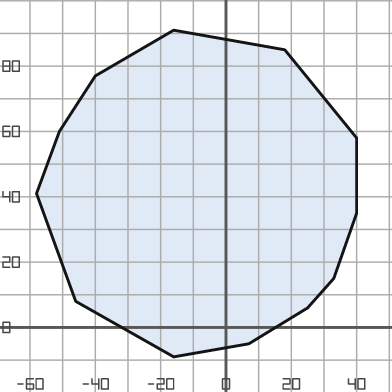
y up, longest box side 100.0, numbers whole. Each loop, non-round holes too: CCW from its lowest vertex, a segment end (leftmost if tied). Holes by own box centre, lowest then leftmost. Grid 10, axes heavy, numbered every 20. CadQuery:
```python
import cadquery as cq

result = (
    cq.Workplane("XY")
    .moveTo(-16.0, -9.0)
    .lineTo(7.0, -5.0)
    .lineTo(25.0, 6.0)
    .lineTo(33.0, 15.0)
    .lineTo(40.0, 35.0)
    .lineTo(40.0, 58.0)
    .lineTo(18.0, 85.0)
    .lineTo(-16.0, 91.0)
    .lineTo(-40.0, 77.0)
    .lineTo(-51.0, 60.0)
    .lineTo(-58.0, 41.0)
    .lineTo(-46.0, 8.0)
    .close()
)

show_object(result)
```